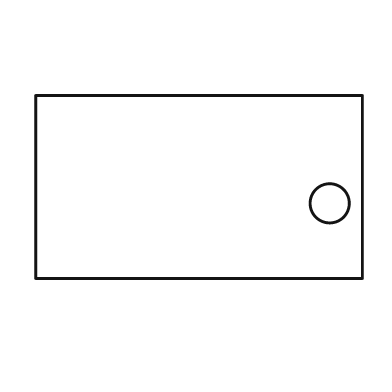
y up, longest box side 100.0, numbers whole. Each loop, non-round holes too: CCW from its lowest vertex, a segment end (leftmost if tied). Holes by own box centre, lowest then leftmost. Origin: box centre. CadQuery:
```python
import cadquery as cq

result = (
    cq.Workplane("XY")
    .moveTo(-50.0, -28.0)
    .lineTo(50.0, -28.0)
    .lineTo(50.0, 28.0)
    .lineTo(-50.0, 28.0)
    .close()
    .moveTo(40.0, -5.0)
    .circle(6.0)
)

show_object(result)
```